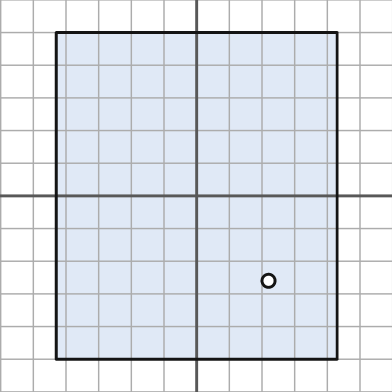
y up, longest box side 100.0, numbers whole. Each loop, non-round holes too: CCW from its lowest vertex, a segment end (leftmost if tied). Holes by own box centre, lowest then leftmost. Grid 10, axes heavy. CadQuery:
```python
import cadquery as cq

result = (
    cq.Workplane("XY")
    .moveTo(-43.0, -50.0)
    .lineTo(43.0, -50.0)
    .lineTo(43.0, 50.0)
    .lineTo(-43.0, 50.0)
    .close()
    .moveTo(22.0, -26.0)
    .circle(2.0)
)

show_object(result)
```